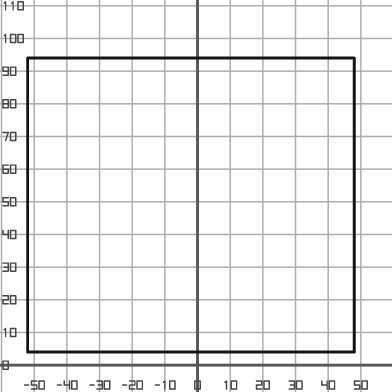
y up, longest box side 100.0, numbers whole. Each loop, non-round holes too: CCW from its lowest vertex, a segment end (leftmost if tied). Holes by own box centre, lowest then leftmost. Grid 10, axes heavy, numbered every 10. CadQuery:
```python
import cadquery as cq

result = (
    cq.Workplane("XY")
    .moveTo(-52.0, 4.0)
    .lineTo(48.0, 4.0)
    .lineTo(48.0, 94.0)
    .lineTo(-52.0, 94.0)
    .close()
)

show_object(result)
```